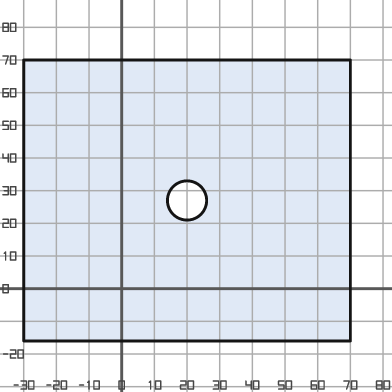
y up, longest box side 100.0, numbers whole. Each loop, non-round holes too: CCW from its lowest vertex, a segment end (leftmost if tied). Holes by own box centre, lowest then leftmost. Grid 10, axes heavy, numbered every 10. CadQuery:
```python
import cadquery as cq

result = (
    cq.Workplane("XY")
    .moveTo(-30.0, -16.0)
    .lineTo(70.0, -16.0)
    .lineTo(70.0, 70.0)
    .lineTo(-30.0, 70.0)
    .close()
    .moveTo(20.0, 27.0)
    .circle(6.0)
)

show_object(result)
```